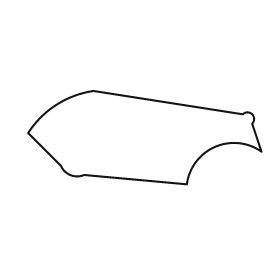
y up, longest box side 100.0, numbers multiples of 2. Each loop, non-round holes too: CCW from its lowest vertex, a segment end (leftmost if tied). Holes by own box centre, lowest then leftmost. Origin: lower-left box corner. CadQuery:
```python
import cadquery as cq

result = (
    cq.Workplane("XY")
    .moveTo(68.0, 0.0)
    .threePointArc((80.0, 16.0), (100.0, 14.0))
    .lineTo(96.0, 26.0)
    .threePointArc((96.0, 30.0), (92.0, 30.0))
    .lineTo(28.0, 40.0)
    .threePointArc((12.0, 34.0), (0.0, 22.0))
    .lineTo(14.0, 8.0)
    .threePointArc((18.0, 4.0), (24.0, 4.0))
    .close()
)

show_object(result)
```